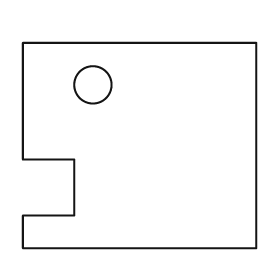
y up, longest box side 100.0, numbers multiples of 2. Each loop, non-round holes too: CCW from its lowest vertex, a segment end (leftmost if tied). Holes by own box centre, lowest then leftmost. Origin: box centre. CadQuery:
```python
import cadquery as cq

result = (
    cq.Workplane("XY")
    .moveTo(-50.0, -44.0)
    .lineTo(50.0, -44.0)
    .lineTo(50.0, 44.0)
    .lineTo(-50.0, 44.0)
    .lineTo(-50.0, -6.0)
    .lineTo(-28.0, -6.0)
    .lineTo(-28.0, -30.0)
    .lineTo(-50.0, -30.0)
    .close()
    .moveTo(-20.0, 26.0)
    .circle(8.0)
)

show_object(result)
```